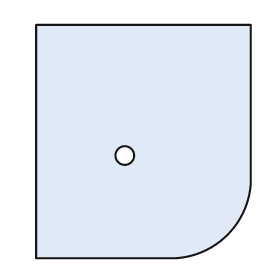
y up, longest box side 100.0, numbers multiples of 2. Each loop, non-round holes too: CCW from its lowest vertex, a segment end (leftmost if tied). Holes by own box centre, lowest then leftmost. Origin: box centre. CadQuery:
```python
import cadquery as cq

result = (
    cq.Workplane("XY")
    .moveTo(-46.0, -50.0)
    .lineTo(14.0, -50.0)
    .threePointArc((36.0, -40.0), (46.0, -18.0))
    .lineTo(46.0, 50.0)
    .lineTo(-46.0, 50.0)
    .close()
    .moveTo(-8.0, -6.0)
    .circle(4.0)
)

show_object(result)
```